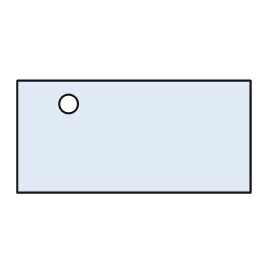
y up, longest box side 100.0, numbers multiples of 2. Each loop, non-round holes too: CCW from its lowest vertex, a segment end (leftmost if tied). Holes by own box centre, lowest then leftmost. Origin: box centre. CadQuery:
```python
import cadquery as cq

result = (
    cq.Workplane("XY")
    .moveTo(-50.0, -24.0)
    .lineTo(50.0, -24.0)
    .lineTo(50.0, 24.0)
    .lineTo(-50.0, 24.0)
    .close()
    .moveTo(-28.0, 14.0)
    .circle(4.0)
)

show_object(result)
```